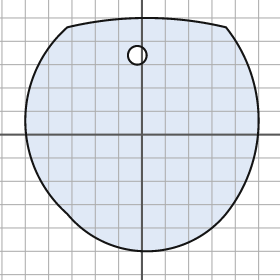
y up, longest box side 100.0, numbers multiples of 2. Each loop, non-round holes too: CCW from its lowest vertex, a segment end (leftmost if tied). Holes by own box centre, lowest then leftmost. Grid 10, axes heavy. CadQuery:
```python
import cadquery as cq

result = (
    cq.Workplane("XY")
    .moveTo(-32.0, -34.0)
    .threePointArc((2.0, -50.0), (36.0, -34.0))
    .threePointArc((50.0, 6.0), (36.0, 46.0))
    .threePointArc((2.0, 50.0), (-32.0, 46.0))
    .threePointArc((-50.0, 6.0), (-32.0, -34.0))
    .close()
    .moveTo(-2.0, 34.0)
    .circle(4.0)
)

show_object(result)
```